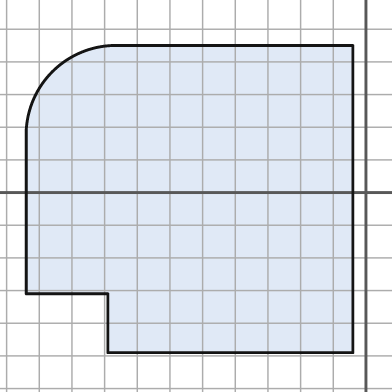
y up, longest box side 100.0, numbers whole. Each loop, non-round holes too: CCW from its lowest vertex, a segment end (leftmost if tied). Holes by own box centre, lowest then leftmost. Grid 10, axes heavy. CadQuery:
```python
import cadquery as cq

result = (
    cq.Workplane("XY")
    .moveTo(-79.0, -49.0)
    .lineTo(-4.0, -49.0)
    .lineTo(-4.0, 45.0)
    .lineTo(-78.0, 45.0)
    .threePointArc((-96.0, 37.0), (-104.0, 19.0))
    .lineTo(-104.0, -31.0)
    .lineTo(-79.0, -31.0)
    .close()
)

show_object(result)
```